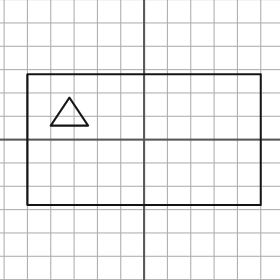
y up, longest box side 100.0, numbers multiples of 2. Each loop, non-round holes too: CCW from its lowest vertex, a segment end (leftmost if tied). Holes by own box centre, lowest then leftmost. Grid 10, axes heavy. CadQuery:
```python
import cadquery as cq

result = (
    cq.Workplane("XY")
    .moveTo(-50.0, -28.0)
    .lineTo(50.0, -28.0)
    .lineTo(50.0, 28.0)
    .lineTo(-50.0, 28.0)
    .close()
    .moveTo(-40.0, 6.0)
    .lineTo(-24.0, 6.0)
    .lineTo(-32.0, 18.0)
    .close()
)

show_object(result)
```